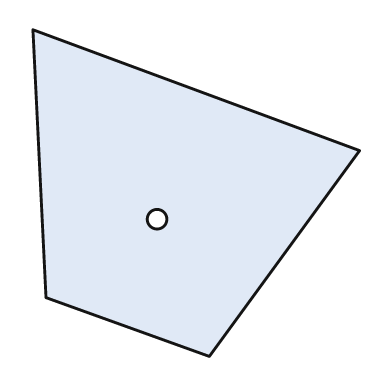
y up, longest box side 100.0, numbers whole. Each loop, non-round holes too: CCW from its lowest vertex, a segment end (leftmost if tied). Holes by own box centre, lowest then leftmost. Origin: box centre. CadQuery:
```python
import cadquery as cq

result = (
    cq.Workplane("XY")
    .moveTo(4.0, -50.0)
    .lineTo(50.0, 13.0)
    .lineTo(-50.0, 50.0)
    .lineTo(-46.0, -32.0)
    .close()
    .moveTo(-12.0, -8.0)
    .circle(3.0)
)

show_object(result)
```